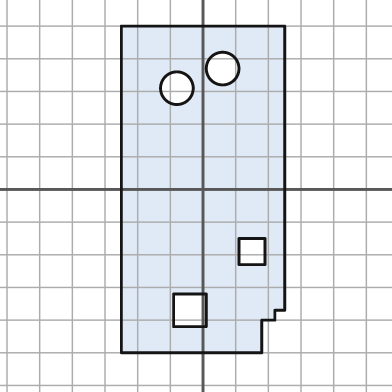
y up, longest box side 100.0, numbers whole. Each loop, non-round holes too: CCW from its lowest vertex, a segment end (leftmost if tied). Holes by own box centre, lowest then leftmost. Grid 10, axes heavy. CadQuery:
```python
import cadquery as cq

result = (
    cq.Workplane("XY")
    .moveTo(-25.0, -50.0)
    .lineTo(18.0, -50.0)
    .lineTo(18.0, -40.0)
    .lineTo(22.0, -40.0)
    .lineTo(22.0, -37.0)
    .lineTo(25.0, -37.0)
    .lineTo(25.0, 50.0)
    .lineTo(-25.0, 50.0)
    .close()
    .moveTo(-9.0, -42.0)
    .lineTo(1.0, -42.0)
    .lineTo(1.0, -32.0)
    .lineTo(-9.0, -32.0)
    .close()
    .moveTo(11.0, -23.0)
    .lineTo(19.0, -23.0)
    .lineTo(19.0, -15.0)
    .lineTo(11.0, -15.0)
    .close()
    .moveTo(-8.0, 31.0)
    .circle(5.0)
    .moveTo(6.0, 37.0)
    .circle(5.0)
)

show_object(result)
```